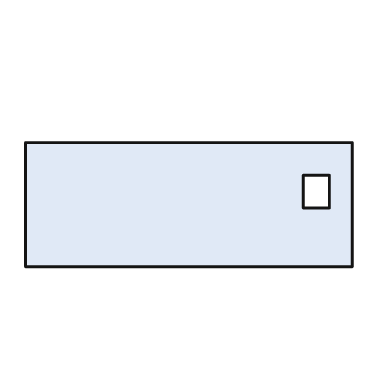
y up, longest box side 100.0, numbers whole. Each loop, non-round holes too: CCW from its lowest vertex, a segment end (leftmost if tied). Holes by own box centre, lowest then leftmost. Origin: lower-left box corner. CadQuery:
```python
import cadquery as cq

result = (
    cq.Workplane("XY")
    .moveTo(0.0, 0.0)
    .lineTo(100.0, 0.0)
    .lineTo(100.0, 38.0)
    .lineTo(0.0, 38.0)
    .close()
    .moveTo(85.0, 18.0)
    .lineTo(93.0, 18.0)
    .lineTo(93.0, 28.0)
    .lineTo(85.0, 28.0)
    .close()
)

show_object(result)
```